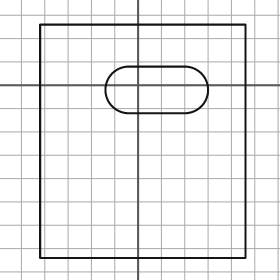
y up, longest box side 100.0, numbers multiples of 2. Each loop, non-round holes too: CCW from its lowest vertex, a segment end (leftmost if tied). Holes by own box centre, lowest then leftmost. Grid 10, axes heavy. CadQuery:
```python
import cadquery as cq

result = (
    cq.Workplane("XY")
    .moveTo(-42.0, -74.0)
    .lineTo(46.0, -74.0)
    .lineTo(46.0, 26.0)
    .lineTo(-42.0, 26.0)
    .close()
    .moveTo(-4.0, -12.0)
    .lineTo(20.0, -12.0)
    .threePointArc((30.0, -2.0), (20.0, 8.0))
    .lineTo(-4.0, 8.0)
    .threePointArc((-14.0, -2.0), (-4.0, -12.0))
    .close()
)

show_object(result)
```